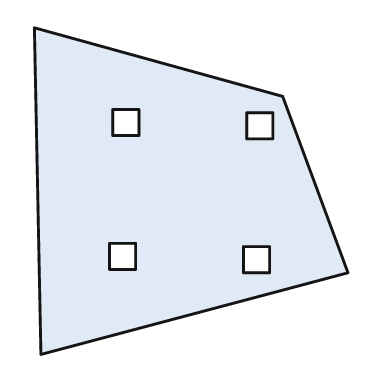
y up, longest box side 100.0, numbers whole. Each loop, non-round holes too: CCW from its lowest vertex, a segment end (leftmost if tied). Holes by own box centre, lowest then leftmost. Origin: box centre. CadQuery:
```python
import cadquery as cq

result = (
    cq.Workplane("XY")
    .moveTo(-46.0, -50.0)
    .lineTo(48.0, -25.0)
    .lineTo(28.0, 29.0)
    .lineTo(-48.0, 50.0)
    .close()
    .moveTo(16.0, -25.0)
    .lineTo(24.0, -25.0)
    .lineTo(24.0, -17.0)
    .lineTo(16.0, -17.0)
    .close()
    .moveTo(-25.0, -24.0)
    .lineTo(-17.0, -24.0)
    .lineTo(-17.0, -16.0)
    .lineTo(-25.0, -16.0)
    .close()
    .moveTo(17.0, 16.0)
    .lineTo(25.0, 16.0)
    .lineTo(25.0, 24.0)
    .lineTo(17.0, 24.0)
    .close()
    .moveTo(-24.0, 17.0)
    .lineTo(-16.0, 17.0)
    .lineTo(-16.0, 25.0)
    .lineTo(-24.0, 25.0)
    .close()
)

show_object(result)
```